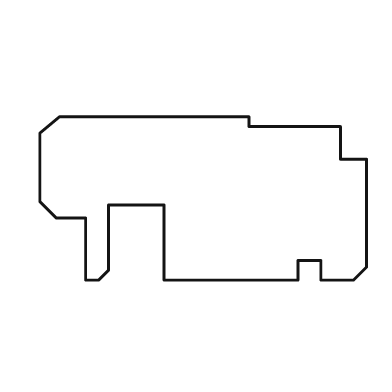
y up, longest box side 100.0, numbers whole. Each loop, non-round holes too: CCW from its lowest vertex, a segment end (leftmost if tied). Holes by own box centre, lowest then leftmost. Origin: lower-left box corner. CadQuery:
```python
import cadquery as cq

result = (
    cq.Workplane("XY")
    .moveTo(14.0, 0.0)
    .lineTo(18.0, 0.0)
    .lineTo(21.0, 3.0)
    .lineTo(21.0, 23.0)
    .lineTo(38.0, 23.0)
    .lineTo(38.0, 0.0)
    .lineTo(79.0, 0.0)
    .lineTo(79.0, 6.0)
    .lineTo(86.0, 6.0)
    .lineTo(86.0, 0.0)
    .lineTo(96.0, 0.0)
    .lineTo(100.0, 4.0)
    .lineTo(100.0, 37.0)
    .lineTo(92.0, 37.0)
    .lineTo(92.0, 47.0)
    .lineTo(64.0, 47.0)
    .lineTo(64.0, 50.0)
    .lineTo(6.0, 50.0)
    .lineTo(0.0, 45.0)
    .lineTo(0.0, 24.0)
    .lineTo(5.0, 19.0)
    .lineTo(14.0, 19.0)
    .close()
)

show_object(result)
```